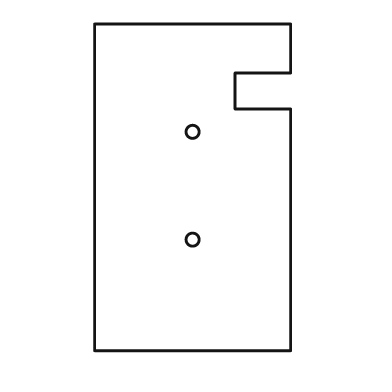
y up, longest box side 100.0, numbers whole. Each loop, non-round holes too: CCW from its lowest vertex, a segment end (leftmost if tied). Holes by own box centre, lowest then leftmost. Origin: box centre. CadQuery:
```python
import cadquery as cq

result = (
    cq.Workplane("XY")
    .moveTo(-30.0, -50.0)
    .lineTo(30.0, -50.0)
    .lineTo(30.0, 24.0)
    .lineTo(13.0, 24.0)
    .lineTo(13.0, 35.0)
    .lineTo(30.0, 35.0)
    .lineTo(30.0, 50.0)
    .lineTo(-30.0, 50.0)
    .close()
    .moveTo(0.0, -16.0)
    .circle(2.0)
    .moveTo(0.0, 17.0)
    .circle(2.0)
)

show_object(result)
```